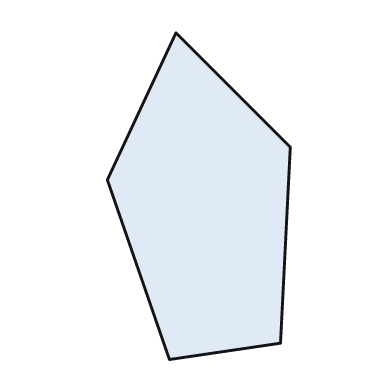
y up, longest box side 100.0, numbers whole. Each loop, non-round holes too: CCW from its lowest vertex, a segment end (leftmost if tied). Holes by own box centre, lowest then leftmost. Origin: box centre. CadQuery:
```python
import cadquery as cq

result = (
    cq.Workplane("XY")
    .moveTo(-9.0, -50.0)
    .lineTo(25.0, -45.0)
    .lineTo(28.0, 15.0)
    .lineTo(-7.0, 50.0)
    .lineTo(-28.0, 5.0)
    .close()
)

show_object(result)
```